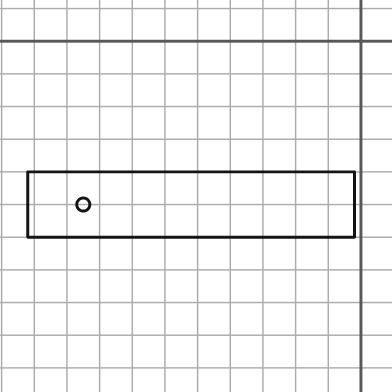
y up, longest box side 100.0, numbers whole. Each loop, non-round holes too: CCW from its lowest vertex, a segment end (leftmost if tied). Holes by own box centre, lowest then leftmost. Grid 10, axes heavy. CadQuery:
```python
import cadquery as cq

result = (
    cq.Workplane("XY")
    .moveTo(-102.0, -60.0)
    .lineTo(-2.0, -60.0)
    .lineTo(-2.0, -40.0)
    .lineTo(-102.0, -40.0)
    .close()
    .moveTo(-85.0, -50.0)
    .circle(2.0)
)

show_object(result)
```